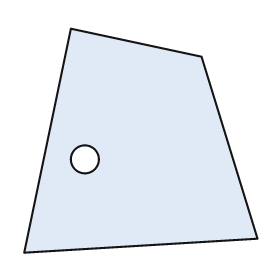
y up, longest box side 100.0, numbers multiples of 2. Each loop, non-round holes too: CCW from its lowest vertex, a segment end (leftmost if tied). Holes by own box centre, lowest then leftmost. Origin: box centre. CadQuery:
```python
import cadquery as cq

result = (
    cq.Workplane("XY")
    .moveTo(-50.0, -48.0)
    .lineTo(50.0, -42.0)
    .lineTo(26.0, 36.0)
    .lineTo(-30.0, 48.0)
    .close()
    .moveTo(-24.0, -8.0)
    .circle(6.0)
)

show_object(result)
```